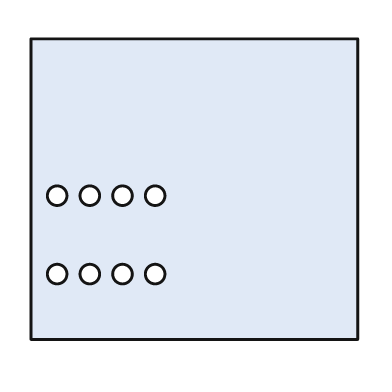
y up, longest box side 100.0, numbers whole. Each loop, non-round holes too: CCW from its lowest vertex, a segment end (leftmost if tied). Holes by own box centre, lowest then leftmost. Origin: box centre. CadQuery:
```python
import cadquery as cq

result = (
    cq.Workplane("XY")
    .moveTo(-50.0, -46.0)
    .lineTo(50.0, -46.0)
    .lineTo(50.0, 46.0)
    .lineTo(-50.0, 46.0)
    .close()
    .moveTo(-42.0, -26.0)
    .circle(3.0)
    .moveTo(-32.0, -26.0)
    .circle(3.0)
    .moveTo(-22.0, -26.0)
    .circle(3.0)
    .moveTo(-12.0, -26.0)
    .circle(3.0)
    .moveTo(-42.0, -2.0)
    .circle(3.0)
    .moveTo(-32.0, -2.0)
    .circle(3.0)
    .moveTo(-22.0, -2.0)
    .circle(3.0)
    .moveTo(-12.0, -2.0)
    .circle(3.0)
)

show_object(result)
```